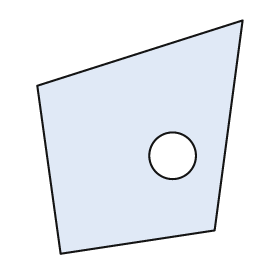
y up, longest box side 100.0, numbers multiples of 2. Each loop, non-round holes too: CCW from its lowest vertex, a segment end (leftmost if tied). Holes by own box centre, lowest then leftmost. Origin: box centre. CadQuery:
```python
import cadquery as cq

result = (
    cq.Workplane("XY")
    .moveTo(-34.0, -50.0)
    .lineTo(32.0, -40.0)
    .lineTo(44.0, 50.0)
    .lineTo(-44.0, 22.0)
    .close()
    .moveTo(14.0, -8.0)
    .circle(10.0)
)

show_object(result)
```